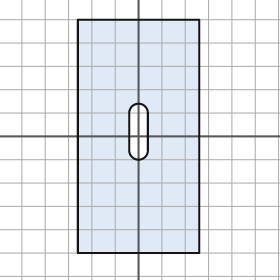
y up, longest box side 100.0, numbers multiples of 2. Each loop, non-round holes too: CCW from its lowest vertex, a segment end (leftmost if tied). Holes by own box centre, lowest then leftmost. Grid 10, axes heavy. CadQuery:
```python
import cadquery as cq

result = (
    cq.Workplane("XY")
    .moveTo(-26.0, -50.0)
    .lineTo(26.0, -50.0)
    .lineTo(26.0, 50.0)
    .lineTo(-26.0, 50.0)
    .close()
    .moveTo(-4.0, -6.0)
    .threePointArc((0.0, -10.0), (4.0, -6.0))
    .lineTo(4.0, 10.0)
    .threePointArc((0.0, 14.0), (-4.0, 10.0))
    .close()
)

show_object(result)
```